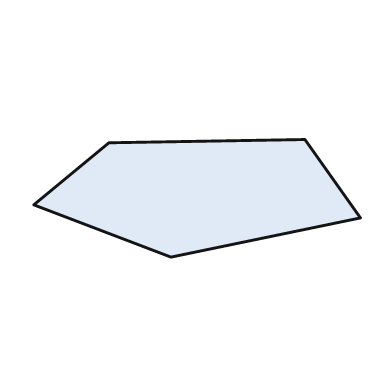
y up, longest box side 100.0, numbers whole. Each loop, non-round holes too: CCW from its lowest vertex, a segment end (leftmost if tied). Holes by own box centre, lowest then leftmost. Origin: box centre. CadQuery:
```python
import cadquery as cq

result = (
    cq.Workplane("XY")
    .moveTo(-8.0, -18.0)
    .lineTo(50.0, -6.0)
    .lineTo(33.0, 18.0)
    .lineTo(-27.0, 17.0)
    .lineTo(-50.0, -2.0)
    .close()
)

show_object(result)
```